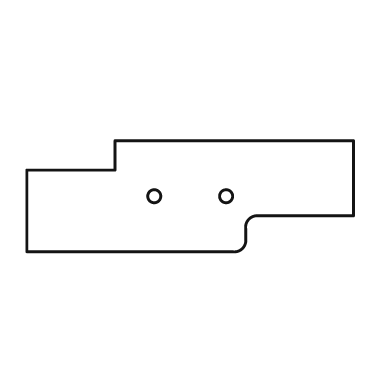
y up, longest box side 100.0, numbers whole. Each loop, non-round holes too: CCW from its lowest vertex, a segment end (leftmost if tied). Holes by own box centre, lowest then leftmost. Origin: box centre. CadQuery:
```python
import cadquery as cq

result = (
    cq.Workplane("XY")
    .moveTo(-50.0, -17.0)
    .lineTo(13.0, -17.0)
    .threePointArc((16.0, -16.0), (17.0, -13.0))
    .lineTo(17.0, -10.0)
    .threePointArc((18.0, -7.0), (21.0, -6.0))
    .lineTo(50.0, -6.0)
    .lineTo(50.0, 17.0)
    .lineTo(-23.0, 17.0)
    .lineTo(-23.0, 8.0)
    .lineTo(-50.0, 8.0)
    .close()
    .moveTo(-11.0, 0.0)
    .circle(2.0)
    .moveTo(11.0, 0.0)
    .circle(2.0)
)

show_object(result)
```